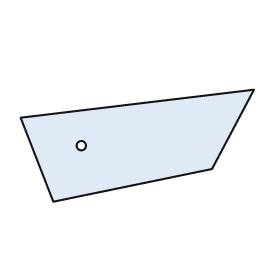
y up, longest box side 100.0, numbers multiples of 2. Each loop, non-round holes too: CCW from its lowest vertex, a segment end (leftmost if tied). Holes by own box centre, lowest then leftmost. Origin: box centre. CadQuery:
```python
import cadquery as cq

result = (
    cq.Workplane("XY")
    .moveTo(-36.0, -24.0)
    .lineTo(32.0, -10.0)
    .lineTo(50.0, 24.0)
    .lineTo(-50.0, 12.0)
    .close()
    .moveTo(-24.0, 0.0)
    .circle(2.0)
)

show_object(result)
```